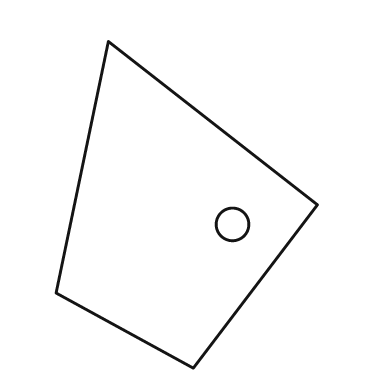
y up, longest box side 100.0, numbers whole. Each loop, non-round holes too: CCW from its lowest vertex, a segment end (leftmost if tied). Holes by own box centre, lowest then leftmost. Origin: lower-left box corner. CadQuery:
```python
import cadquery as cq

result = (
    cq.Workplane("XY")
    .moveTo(42.0, 0.0)
    .lineTo(80.0, 50.0)
    .lineTo(16.0, 100.0)
    .lineTo(0.0, 23.0)
    .close()
    .moveTo(54.0, 44.0)
    .circle(5.0)
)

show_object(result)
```